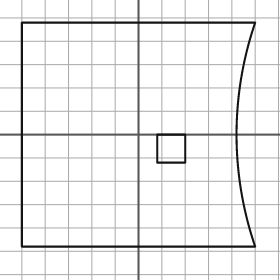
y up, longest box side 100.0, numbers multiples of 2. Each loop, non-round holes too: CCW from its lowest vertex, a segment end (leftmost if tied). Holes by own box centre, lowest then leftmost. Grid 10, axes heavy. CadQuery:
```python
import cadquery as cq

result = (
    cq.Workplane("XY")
    .moveTo(-50.0, -48.0)
    .lineTo(50.0, -48.0)
    .threePointArc((42.0, 0.0), (50.0, 48.0))
    .lineTo(-50.0, 48.0)
    .close()
    .moveTo(8.0, -12.0)
    .lineTo(20.0, -12.0)
    .lineTo(20.0, 0.0)
    .lineTo(8.0, 0.0)
    .close()
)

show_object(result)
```